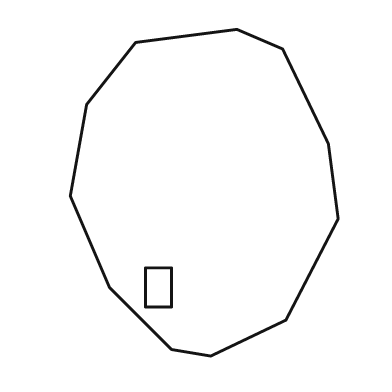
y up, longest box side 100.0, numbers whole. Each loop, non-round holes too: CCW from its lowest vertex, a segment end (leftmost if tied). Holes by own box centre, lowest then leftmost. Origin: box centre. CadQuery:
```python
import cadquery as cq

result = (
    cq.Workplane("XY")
    .moveTo(2.0, -50.0)
    .lineTo(25.0, -39.0)
    .lineTo(41.0, -8.0)
    .lineTo(38.0, 15.0)
    .lineTo(24.0, 44.0)
    .lineTo(10.0, 50.0)
    .lineTo(-21.0, 46.0)
    .lineTo(-36.0, 27.0)
    .lineTo(-41.0, -1.0)
    .lineTo(-29.0, -29.0)
    .lineTo(-10.0, -48.0)
    .close()
    .moveTo(-18.0, -35.0)
    .lineTo(-10.0, -35.0)
    .lineTo(-10.0, -23.0)
    .lineTo(-18.0, -23.0)
    .close()
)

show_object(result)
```